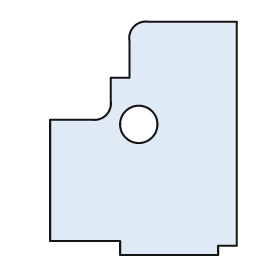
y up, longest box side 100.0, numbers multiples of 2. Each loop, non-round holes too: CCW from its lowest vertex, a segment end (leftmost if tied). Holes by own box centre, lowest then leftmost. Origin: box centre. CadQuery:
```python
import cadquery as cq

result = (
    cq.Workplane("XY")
    .moveTo(-10.0, -50.0)
    .lineTo(32.0, -50.0)
    .lineTo(32.0, -46.0)
    .lineTo(40.0, -46.0)
    .lineTo(40.0, 50.0)
    .lineTo(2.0, 50.0)
    .threePointArc((-4.0, 48.0), (-6.0, 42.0))
    .lineTo(-6.0, 26.0)
    .lineTo(-14.0, 26.0)
    .lineTo(-14.0, 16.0)
    .threePointArc((-16.0, 10.0), (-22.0, 8.0))
    .lineTo(-40.0, 8.0)
    .lineTo(-40.0, -44.0)
    .lineTo(-10.0, -44.0)
    .close()
    .moveTo(-2.0, 6.0)
    .circle(8.0)
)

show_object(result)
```